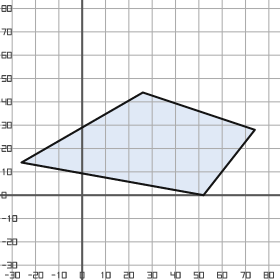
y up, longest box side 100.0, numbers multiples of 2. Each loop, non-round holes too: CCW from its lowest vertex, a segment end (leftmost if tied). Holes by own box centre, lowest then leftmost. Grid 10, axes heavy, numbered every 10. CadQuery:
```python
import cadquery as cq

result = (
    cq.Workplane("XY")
    .moveTo(52.0, 0.0)
    .lineTo(74.0, 28.0)
    .lineTo(26.0, 44.0)
    .lineTo(-26.0, 14.0)
    .close()
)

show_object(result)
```